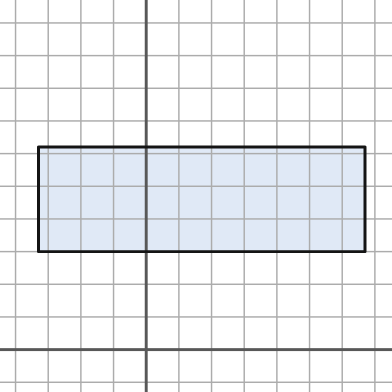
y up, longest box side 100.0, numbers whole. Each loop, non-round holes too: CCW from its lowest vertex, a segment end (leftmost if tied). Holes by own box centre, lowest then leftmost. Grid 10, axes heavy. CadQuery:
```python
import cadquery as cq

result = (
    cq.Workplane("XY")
    .moveTo(-33.0, 30.0)
    .lineTo(67.0, 30.0)
    .lineTo(67.0, 62.0)
    .lineTo(-33.0, 62.0)
    .close()
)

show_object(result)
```